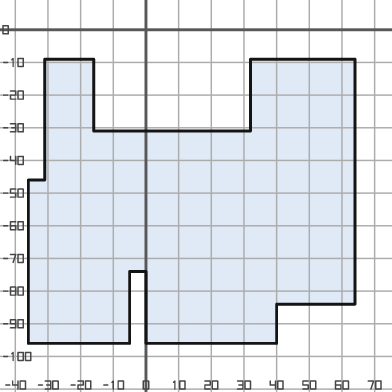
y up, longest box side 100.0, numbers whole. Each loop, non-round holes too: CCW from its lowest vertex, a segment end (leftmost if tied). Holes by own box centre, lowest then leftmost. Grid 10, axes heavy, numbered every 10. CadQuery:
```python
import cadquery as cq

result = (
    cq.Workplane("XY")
    .moveTo(-36.0, -96.0)
    .lineTo(-5.0, -96.0)
    .lineTo(-5.0, -74.0)
    .lineTo(0.0, -74.0)
    .lineTo(0.0, -96.0)
    .lineTo(40.0, -96.0)
    .lineTo(40.0, -84.0)
    .lineTo(64.0, -84.0)
    .lineTo(64.0, -9.0)
    .lineTo(32.0, -9.0)
    .lineTo(32.0, -31.0)
    .lineTo(-16.0, -31.0)
    .lineTo(-16.0, -9.0)
    .lineTo(-31.0, -9.0)
    .lineTo(-31.0, -46.0)
    .lineTo(-36.0, -46.0)
    .close()
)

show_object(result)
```